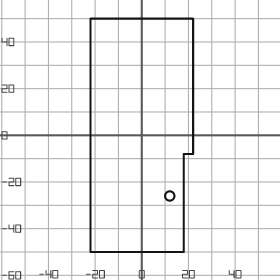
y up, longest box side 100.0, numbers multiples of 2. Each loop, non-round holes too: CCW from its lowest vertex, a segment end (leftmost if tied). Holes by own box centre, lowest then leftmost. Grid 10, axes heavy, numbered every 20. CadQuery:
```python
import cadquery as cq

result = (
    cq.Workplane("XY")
    .moveTo(-22.0, -50.0)
    .lineTo(18.0, -50.0)
    .lineTo(18.0, -8.0)
    .lineTo(22.0, -8.0)
    .lineTo(22.0, 50.0)
    .lineTo(-22.0, 50.0)
    .close()
    .moveTo(12.0, -26.0)
    .circle(2.0)
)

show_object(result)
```